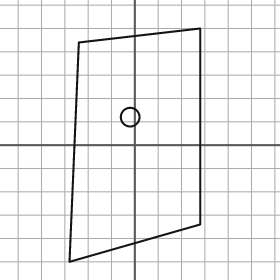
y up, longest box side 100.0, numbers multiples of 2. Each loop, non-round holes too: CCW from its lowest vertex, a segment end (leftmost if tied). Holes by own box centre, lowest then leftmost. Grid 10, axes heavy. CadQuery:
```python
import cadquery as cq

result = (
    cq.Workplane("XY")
    .moveTo(-28.0, -50.0)
    .lineTo(28.0, -34.0)
    .lineTo(28.0, 50.0)
    .lineTo(-24.0, 44.0)
    .close()
    .moveTo(-2.0, 12.0)
    .circle(4.0)
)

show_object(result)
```